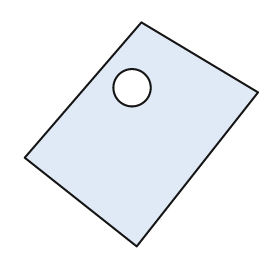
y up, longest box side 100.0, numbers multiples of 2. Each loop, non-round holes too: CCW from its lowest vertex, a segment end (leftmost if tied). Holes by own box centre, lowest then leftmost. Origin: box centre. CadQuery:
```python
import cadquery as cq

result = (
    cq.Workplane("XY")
    .moveTo(-2.0, -48.0)
    .lineTo(50.0, 18.0)
    .lineTo(0.0, 48.0)
    .lineTo(-50.0, -10.0)
    .close()
    .moveTo(-4.0, 20.0)
    .circle(8.0)
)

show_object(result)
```